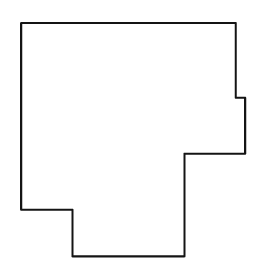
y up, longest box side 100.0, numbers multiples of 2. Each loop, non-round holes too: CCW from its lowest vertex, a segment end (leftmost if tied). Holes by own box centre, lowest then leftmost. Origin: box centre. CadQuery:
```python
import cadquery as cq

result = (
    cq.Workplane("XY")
    .moveTo(-26.0, -50.0)
    .lineTo(22.0, -50.0)
    .lineTo(22.0, -6.0)
    .lineTo(48.0, -6.0)
    .lineTo(48.0, 18.0)
    .lineTo(44.0, 18.0)
    .lineTo(44.0, 50.0)
    .lineTo(-48.0, 50.0)
    .lineTo(-48.0, -30.0)
    .lineTo(-26.0, -30.0)
    .close()
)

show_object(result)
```